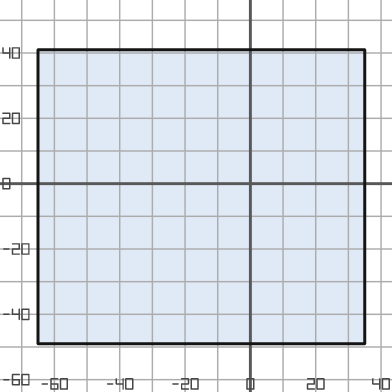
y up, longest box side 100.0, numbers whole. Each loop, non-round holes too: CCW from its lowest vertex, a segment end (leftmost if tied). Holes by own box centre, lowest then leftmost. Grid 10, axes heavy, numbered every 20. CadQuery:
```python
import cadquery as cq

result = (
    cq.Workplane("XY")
    .moveTo(-65.0, -49.0)
    .lineTo(35.0, -49.0)
    .lineTo(35.0, 41.0)
    .lineTo(-65.0, 41.0)
    .close()
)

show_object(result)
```